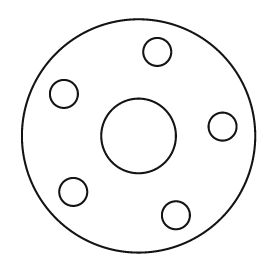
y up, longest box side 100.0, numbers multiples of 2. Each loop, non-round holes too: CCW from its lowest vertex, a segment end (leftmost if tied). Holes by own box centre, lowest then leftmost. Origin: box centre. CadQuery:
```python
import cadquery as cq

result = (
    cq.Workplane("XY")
    .moveTo(0.0, 0.0)
    .circle(50.0)
    .moveTo(16.0, -34.0)
    .circle(6.0)
    .moveTo(-28.0, -24.0)
    .circle(6.0)
    .moveTo(0.0, 0.0)
    .circle(16.0)
    .moveTo(36.0, 4.0)
    .circle(6.0)
    .moveTo(-32.0, 18.0)
    .circle(6.0)
    .moveTo(8.0, 36.0)
    .circle(6.0)
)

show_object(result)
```